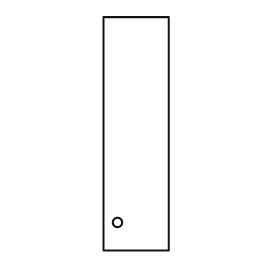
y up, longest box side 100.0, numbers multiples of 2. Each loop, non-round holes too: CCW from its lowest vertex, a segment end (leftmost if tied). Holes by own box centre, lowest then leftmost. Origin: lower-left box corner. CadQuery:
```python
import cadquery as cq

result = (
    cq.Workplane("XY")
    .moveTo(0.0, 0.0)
    .lineTo(28.0, 0.0)
    .lineTo(28.0, 100.0)
    .lineTo(0.0, 100.0)
    .close()
    .moveTo(6.0, 12.0)
    .circle(2.0)
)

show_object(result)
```